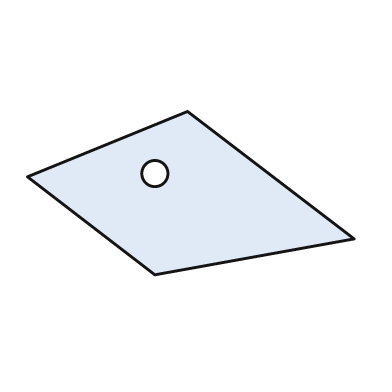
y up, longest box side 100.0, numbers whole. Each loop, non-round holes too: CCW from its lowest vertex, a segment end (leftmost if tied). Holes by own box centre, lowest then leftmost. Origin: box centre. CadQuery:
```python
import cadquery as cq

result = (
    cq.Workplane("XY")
    .moveTo(-11.0, -25.0)
    .lineTo(50.0, -14.0)
    .lineTo(-1.0, 25.0)
    .lineTo(-50.0, 5.0)
    .close()
    .moveTo(-11.0, 6.0)
    .circle(4.0)
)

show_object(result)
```